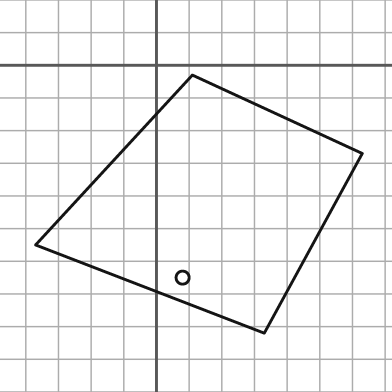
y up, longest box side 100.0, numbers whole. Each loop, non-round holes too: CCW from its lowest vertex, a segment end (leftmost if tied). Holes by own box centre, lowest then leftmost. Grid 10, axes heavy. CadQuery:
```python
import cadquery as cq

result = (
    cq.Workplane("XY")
    .moveTo(33.0, -82.0)
    .lineTo(63.0, -27.0)
    .lineTo(11.0, -3.0)
    .lineTo(-37.0, -55.0)
    .close()
    .moveTo(8.0, -65.0)
    .circle(2.0)
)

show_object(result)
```